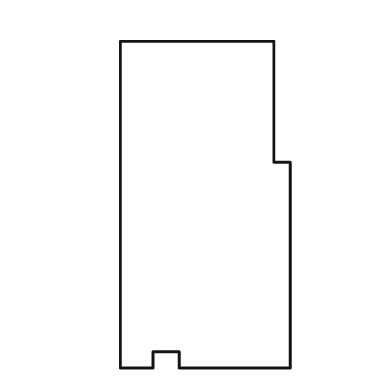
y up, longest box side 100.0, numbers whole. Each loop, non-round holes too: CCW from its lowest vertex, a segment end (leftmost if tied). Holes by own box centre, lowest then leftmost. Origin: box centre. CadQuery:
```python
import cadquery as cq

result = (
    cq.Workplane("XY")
    .moveTo(-26.0, -50.0)
    .lineTo(-16.0, -50.0)
    .lineTo(-16.0, -45.0)
    .lineTo(-8.0, -45.0)
    .lineTo(-8.0, -50.0)
    .lineTo(26.0, -50.0)
    .lineTo(26.0, 13.0)
    .lineTo(21.0, 13.0)
    .lineTo(21.0, 50.0)
    .lineTo(-26.0, 50.0)
    .close()
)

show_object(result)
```